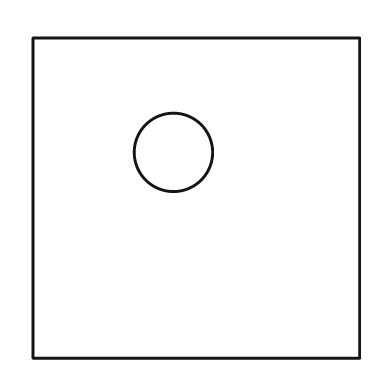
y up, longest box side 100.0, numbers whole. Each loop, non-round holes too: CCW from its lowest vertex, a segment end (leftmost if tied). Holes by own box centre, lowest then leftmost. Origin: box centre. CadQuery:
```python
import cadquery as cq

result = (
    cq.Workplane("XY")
    .moveTo(-50.0, -49.0)
    .lineTo(50.0, -49.0)
    .lineTo(50.0, 49.0)
    .lineTo(-50.0, 49.0)
    .close()
    .moveTo(-7.0, 14.0)
    .circle(12.0)
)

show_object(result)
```